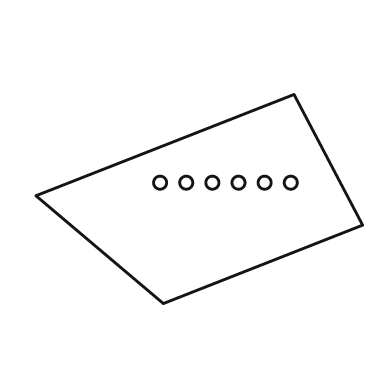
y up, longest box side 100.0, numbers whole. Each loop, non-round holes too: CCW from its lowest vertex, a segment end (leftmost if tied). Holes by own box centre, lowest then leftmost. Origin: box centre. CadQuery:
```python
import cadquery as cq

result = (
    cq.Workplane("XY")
    .moveTo(-11.0, -32.0)
    .lineTo(50.0, -8.0)
    .lineTo(29.0, 32.0)
    .lineTo(-50.0, 1.0)
    .close()
    .moveTo(-12.0, 5.0)
    .circle(2.0)
    .moveTo(-4.0, 5.0)
    .circle(2.0)
    .moveTo(4.0, 5.0)
    .circle(2.0)
    .moveTo(12.0, 5.0)
    .circle(2.0)
    .moveTo(20.0, 5.0)
    .circle(2.0)
    .moveTo(28.0, 5.0)
    .circle(2.0)
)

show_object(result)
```